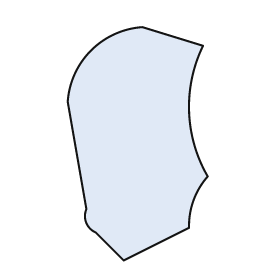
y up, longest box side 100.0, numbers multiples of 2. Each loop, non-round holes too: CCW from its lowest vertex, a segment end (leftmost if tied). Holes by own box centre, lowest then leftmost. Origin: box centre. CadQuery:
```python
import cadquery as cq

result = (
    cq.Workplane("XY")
    .moveTo(-6.0, -50.0)
    .lineTo(22.0, -36.0)
    .threePointArc((24.0, -24.0), (30.0, -14.0))
    .threePointArc((22.0, 14.0), (28.0, 42.0))
    .lineTo(2.0, 50.0)
    .threePointArc((-20.0, 40.0), (-30.0, 18.0))
    .lineTo(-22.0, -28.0)
    .threePointArc((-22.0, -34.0), (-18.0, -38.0))
    .close()
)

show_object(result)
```